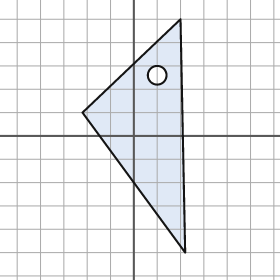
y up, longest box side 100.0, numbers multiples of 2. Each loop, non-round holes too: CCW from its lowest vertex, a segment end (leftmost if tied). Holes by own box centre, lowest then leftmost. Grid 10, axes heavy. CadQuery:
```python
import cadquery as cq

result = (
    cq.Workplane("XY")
    .moveTo(22.0, -50.0)
    .lineTo(20.0, 50.0)
    .lineTo(-22.0, 10.0)
    .close()
    .moveTo(10.0, 26.0)
    .circle(4.0)
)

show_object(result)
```